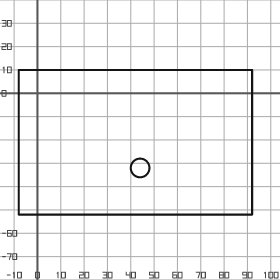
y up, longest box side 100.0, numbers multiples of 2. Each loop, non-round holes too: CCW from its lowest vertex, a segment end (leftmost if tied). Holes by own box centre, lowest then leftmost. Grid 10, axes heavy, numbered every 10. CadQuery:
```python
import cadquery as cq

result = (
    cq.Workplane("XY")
    .moveTo(-8.0, -52.0)
    .lineTo(92.0, -52.0)
    .lineTo(92.0, 10.0)
    .lineTo(-8.0, 10.0)
    .close()
    .moveTo(44.0, -32.0)
    .circle(4.0)
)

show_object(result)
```